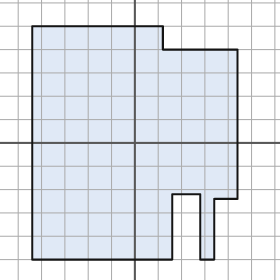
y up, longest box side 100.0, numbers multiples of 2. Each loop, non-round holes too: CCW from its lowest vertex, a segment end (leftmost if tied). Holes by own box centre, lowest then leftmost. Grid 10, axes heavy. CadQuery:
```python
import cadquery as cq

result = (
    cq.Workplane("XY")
    .moveTo(-44.0, -50.0)
    .lineTo(16.0, -50.0)
    .lineTo(16.0, -22.0)
    .lineTo(28.0, -22.0)
    .lineTo(28.0, -50.0)
    .lineTo(34.0, -50.0)
    .lineTo(34.0, -24.0)
    .lineTo(44.0, -24.0)
    .lineTo(44.0, 40.0)
    .lineTo(12.0, 40.0)
    .lineTo(12.0, 50.0)
    .lineTo(-44.0, 50.0)
    .close()
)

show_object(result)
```